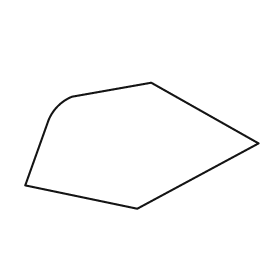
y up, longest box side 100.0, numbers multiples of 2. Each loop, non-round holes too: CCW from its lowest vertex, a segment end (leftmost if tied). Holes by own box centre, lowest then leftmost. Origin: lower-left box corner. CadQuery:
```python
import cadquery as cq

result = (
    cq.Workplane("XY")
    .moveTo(48.0, 0.0)
    .lineTo(100.0, 28.0)
    .lineTo(54.0, 54.0)
    .lineTo(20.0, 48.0)
    .threePointArc((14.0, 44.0), (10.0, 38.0))
    .lineTo(0.0, 10.0)
    .close()
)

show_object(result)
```